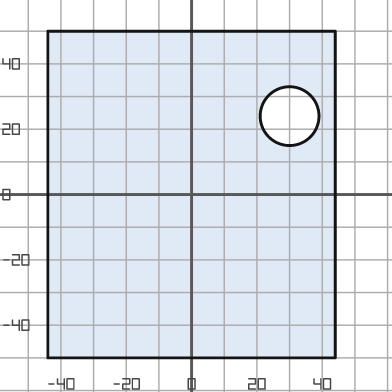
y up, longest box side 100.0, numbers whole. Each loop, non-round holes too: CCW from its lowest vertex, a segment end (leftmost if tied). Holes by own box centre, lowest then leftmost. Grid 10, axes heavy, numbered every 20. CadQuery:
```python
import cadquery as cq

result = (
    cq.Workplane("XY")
    .moveTo(-44.0, -50.0)
    .lineTo(44.0, -50.0)
    .lineTo(44.0, 50.0)
    .lineTo(-44.0, 50.0)
    .close()
    .moveTo(30.0, 24.0)
    .circle(9.0)
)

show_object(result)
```